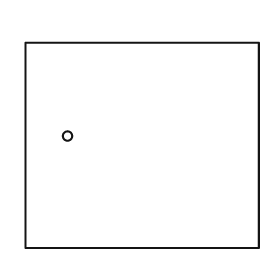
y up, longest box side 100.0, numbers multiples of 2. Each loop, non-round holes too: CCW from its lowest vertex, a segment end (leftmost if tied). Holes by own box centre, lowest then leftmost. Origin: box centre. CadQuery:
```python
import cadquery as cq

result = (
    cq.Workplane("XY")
    .moveTo(-50.0, -44.0)
    .lineTo(50.0, -44.0)
    .lineTo(50.0, 44.0)
    .lineTo(-50.0, 44.0)
    .close()
    .moveTo(-32.0, 4.0)
    .circle(2.0)
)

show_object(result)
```